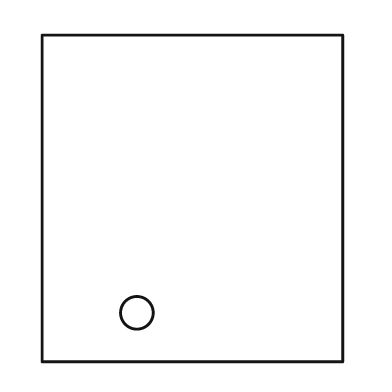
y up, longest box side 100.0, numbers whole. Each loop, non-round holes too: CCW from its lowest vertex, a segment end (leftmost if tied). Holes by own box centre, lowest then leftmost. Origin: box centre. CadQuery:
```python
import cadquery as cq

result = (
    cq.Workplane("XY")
    .moveTo(-46.0, -50.0)
    .lineTo(46.0, -50.0)
    .lineTo(46.0, 50.0)
    .lineTo(-46.0, 50.0)
    .close()
    .moveTo(-17.0, -35.0)
    .circle(5.0)
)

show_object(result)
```